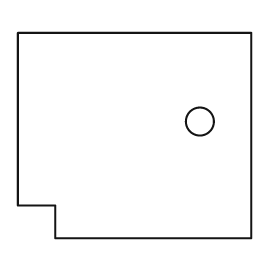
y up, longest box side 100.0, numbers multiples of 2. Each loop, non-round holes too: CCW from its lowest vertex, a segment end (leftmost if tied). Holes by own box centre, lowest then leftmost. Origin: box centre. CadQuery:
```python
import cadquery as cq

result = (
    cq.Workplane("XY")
    .moveTo(-34.0, -44.0)
    .lineTo(50.0, -44.0)
    .lineTo(50.0, 44.0)
    .lineTo(-50.0, 44.0)
    .lineTo(-50.0, -30.0)
    .lineTo(-34.0, -30.0)
    .close()
    .moveTo(28.0, 6.0)
    .circle(6.0)
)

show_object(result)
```